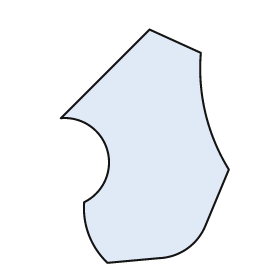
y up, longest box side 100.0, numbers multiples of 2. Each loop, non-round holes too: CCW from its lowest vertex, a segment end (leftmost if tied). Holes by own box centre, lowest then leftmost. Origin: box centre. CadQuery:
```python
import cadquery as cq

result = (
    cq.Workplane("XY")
    .moveTo(-16.0, -50.0)
    .lineTo(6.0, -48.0)
    .threePointArc((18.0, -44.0), (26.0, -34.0))
    .lineTo(36.0, -10.0)
    .threePointArc((26.0, 14.0), (24.0, 40.0))
    .lineTo(2.0, 50.0)
    .lineTo(-36.0, 12.0)
    .threePointArc((-16.0, -2.0), (-26.0, -24.0))
    .threePointArc((-24.0, -38.0), (-16.0, -50.0))
    .close()
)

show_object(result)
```